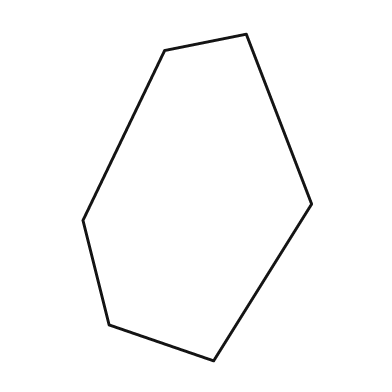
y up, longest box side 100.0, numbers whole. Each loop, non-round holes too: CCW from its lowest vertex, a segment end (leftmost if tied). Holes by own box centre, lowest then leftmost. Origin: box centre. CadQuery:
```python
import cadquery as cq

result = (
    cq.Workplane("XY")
    .moveTo(5.0, -50.0)
    .lineTo(35.0, -2.0)
    .lineTo(15.0, 50.0)
    .lineTo(-10.0, 45.0)
    .lineTo(-35.0, -7.0)
    .lineTo(-27.0, -39.0)
    .close()
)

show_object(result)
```